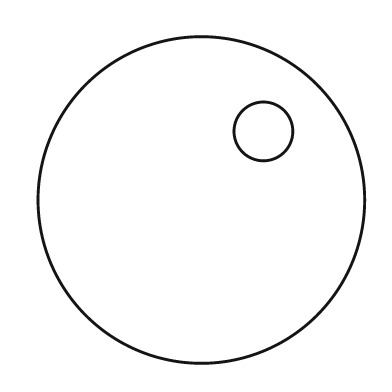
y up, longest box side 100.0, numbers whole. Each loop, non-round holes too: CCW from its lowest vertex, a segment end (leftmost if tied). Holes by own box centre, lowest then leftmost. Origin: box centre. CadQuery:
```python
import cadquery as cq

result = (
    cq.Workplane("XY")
    .moveTo(0.0, 0.0)
    .circle(50.0)
    .moveTo(19.0, 21.0)
    .circle(9.0)
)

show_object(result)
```